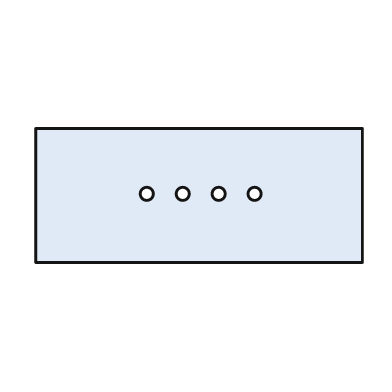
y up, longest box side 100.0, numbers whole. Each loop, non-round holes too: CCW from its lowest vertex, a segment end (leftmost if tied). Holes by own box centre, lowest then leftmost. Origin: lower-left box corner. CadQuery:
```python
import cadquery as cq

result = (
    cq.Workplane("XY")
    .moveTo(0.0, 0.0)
    .lineTo(100.0, 0.0)
    .lineTo(100.0, 41.0)
    .lineTo(0.0, 41.0)
    .close()
    .moveTo(34.0, 21.0)
    .circle(2.0)
    .moveTo(45.0, 21.0)
    .circle(2.0)
    .moveTo(56.0, 21.0)
    .circle(2.0)
    .moveTo(67.0, 21.0)
    .circle(2.0)
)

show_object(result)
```